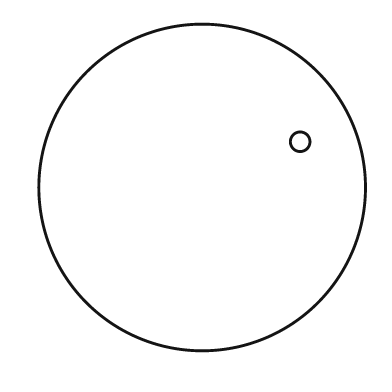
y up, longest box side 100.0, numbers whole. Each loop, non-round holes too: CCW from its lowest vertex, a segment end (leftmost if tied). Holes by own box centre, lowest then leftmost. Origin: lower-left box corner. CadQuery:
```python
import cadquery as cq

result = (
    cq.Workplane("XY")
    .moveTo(50.0, 50.0)
    .circle(50.0)
    .moveTo(80.0, 64.0)
    .circle(3.0)
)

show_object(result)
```